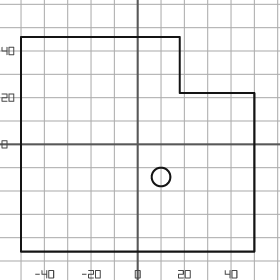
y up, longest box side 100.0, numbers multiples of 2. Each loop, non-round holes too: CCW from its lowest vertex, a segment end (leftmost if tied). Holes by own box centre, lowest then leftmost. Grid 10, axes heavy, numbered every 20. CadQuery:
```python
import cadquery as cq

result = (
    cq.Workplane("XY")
    .moveTo(-50.0, -46.0)
    .lineTo(50.0, -46.0)
    .lineTo(50.0, 22.0)
    .lineTo(18.0, 22.0)
    .lineTo(18.0, 46.0)
    .lineTo(-50.0, 46.0)
    .close()
    .moveTo(10.0, -14.0)
    .circle(4.0)
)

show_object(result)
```